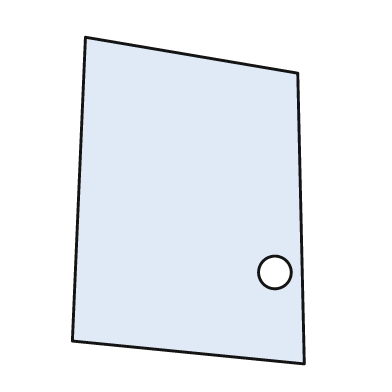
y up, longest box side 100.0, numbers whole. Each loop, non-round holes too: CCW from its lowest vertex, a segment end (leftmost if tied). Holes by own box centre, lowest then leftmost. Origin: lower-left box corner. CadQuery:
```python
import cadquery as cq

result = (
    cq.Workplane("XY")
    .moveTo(71.0, 0.0)
    .lineTo(69.0, 89.0)
    .lineTo(4.0, 100.0)
    .lineTo(0.0, 7.0)
    .close()
    .moveTo(62.0, 28.0)
    .circle(5.0)
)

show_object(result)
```